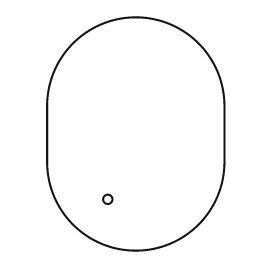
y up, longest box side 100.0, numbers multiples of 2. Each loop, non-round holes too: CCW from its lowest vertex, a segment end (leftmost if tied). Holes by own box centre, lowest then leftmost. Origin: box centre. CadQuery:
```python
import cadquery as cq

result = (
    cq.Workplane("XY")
    .moveTo(-38.0, -12.0)
    .threePointArc((0.0, -50.0), (38.0, -12.0))
    .lineTo(38.0, 12.0)
    .threePointArc((0.0, 50.0), (-38.0, 12.0))
    .close()
    .moveTo(-12.0, -28.0)
    .circle(2.0)
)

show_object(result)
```